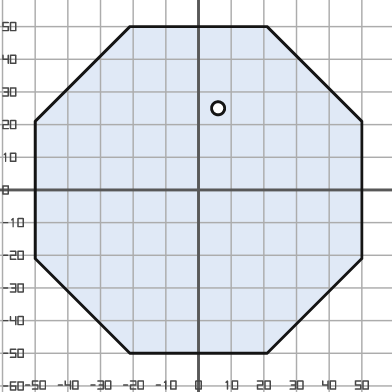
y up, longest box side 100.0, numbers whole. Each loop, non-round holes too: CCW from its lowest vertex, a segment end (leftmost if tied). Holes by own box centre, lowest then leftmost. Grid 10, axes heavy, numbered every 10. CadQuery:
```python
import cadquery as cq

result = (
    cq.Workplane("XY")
    .moveTo(-21.0, -50.0)
    .lineTo(21.0, -50.0)
    .lineTo(50.0, -21.0)
    .lineTo(50.0, 21.0)
    .lineTo(21.0, 50.0)
    .lineTo(-21.0, 50.0)
    .lineTo(-50.0, 21.0)
    .lineTo(-50.0, -21.0)
    .close()
    .moveTo(6.0, 25.0)
    .circle(2.0)
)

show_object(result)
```